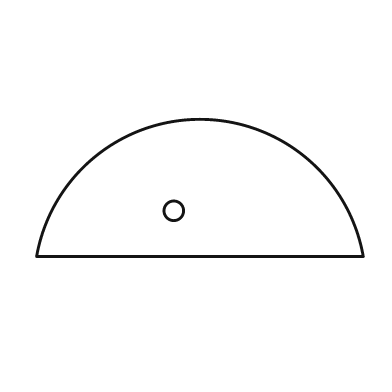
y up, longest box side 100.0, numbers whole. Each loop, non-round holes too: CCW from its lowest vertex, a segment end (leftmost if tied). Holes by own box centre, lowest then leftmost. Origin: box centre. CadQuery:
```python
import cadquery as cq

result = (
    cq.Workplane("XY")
    .moveTo(-50.0, -21.0)
    .lineTo(50.0, -21.0)
    .threePointArc((0.0, 21.0), (-50.0, -21.0))
    .close()
    .moveTo(-8.0, -7.0)
    .circle(3.0)
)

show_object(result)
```